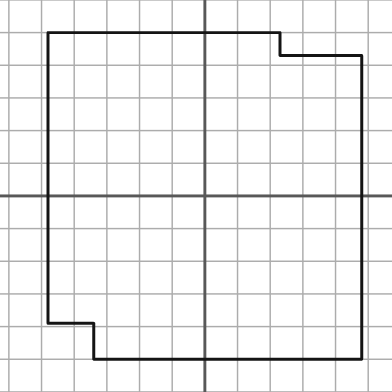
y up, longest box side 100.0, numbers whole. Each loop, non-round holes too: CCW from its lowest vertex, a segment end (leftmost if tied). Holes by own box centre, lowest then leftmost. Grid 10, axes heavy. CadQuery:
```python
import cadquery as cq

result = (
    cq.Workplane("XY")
    .moveTo(-34.0, -50.0)
    .lineTo(48.0, -50.0)
    .lineTo(48.0, 43.0)
    .lineTo(23.0, 43.0)
    .lineTo(23.0, 50.0)
    .lineTo(-48.0, 50.0)
    .lineTo(-48.0, -39.0)
    .lineTo(-34.0, -39.0)
    .close()
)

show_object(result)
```